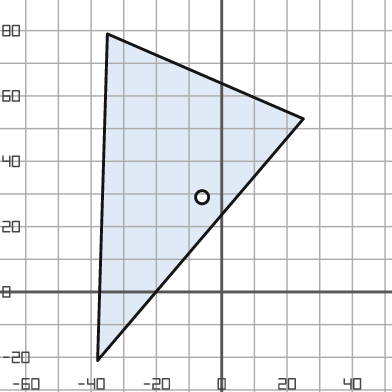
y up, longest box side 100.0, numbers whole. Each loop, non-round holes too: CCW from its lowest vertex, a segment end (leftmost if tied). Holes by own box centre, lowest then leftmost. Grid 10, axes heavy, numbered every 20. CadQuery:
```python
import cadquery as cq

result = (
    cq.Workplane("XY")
    .moveTo(-38.0, -21.0)
    .lineTo(25.0, 53.0)
    .lineTo(-35.0, 79.0)
    .close()
    .moveTo(-6.0, 29.0)
    .circle(2.0)
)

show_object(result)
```